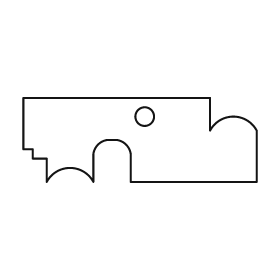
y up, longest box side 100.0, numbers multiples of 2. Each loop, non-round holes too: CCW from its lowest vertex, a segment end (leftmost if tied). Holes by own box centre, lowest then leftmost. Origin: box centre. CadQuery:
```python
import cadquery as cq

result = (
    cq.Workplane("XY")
    .moveTo(-40.0, -18.0)
    .threePointArc((-30.0, -12.0), (-20.0, -18.0))
    .lineTo(-20.0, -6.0)
    .threePointArc((-18.0, -2.0), (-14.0, 0.0))
    .lineTo(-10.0, 0.0)
    .threePointArc((-6.0, -2.0), (-4.0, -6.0))
    .lineTo(-4.0, -18.0)
    .lineTo(50.0, -18.0)
    .lineTo(50.0, 4.0)
    .threePointArc((40.0, 10.0), (30.0, 4.0))
    .lineTo(30.0, 18.0)
    .lineTo(-50.0, 18.0)
    .lineTo(-50.0, -4.0)
    .lineTo(-46.0, -4.0)
    .lineTo(-46.0, -8.0)
    .lineTo(-40.0, -8.0)
    .close()
    .moveTo(2.0, 10.0)
    .circle(4.0)
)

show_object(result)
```